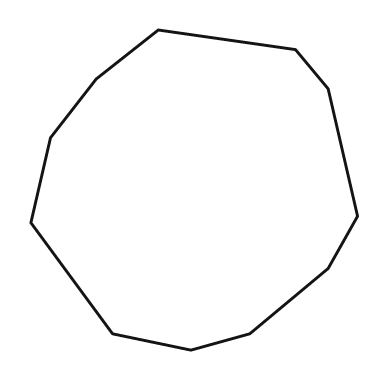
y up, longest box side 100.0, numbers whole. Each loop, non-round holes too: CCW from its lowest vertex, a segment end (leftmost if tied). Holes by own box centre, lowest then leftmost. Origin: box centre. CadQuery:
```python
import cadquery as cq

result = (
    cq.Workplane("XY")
    .moveTo(-1.0, -49.0)
    .lineTo(17.0, -44.0)
    .lineTo(41.0, -24.0)
    .lineTo(50.0, -8.0)
    .lineTo(41.0, 31.0)
    .lineTo(31.0, 43.0)
    .lineTo(-11.0, 49.0)
    .lineTo(-30.0, 34.0)
    .lineTo(-44.0, 16.0)
    .lineTo(-50.0, -10.0)
    .lineTo(-25.0, -44.0)
    .close()
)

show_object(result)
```